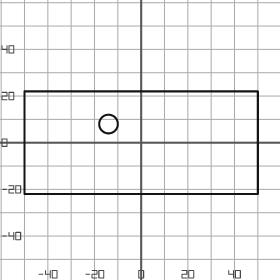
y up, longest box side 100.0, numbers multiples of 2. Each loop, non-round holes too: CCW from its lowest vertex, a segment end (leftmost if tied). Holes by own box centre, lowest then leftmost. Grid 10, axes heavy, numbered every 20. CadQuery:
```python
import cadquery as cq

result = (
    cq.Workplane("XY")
    .moveTo(-50.0, -22.0)
    .lineTo(50.0, -22.0)
    .lineTo(50.0, 22.0)
    .lineTo(-50.0, 22.0)
    .close()
    .moveTo(-14.0, 8.0)
    .circle(4.0)
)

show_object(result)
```